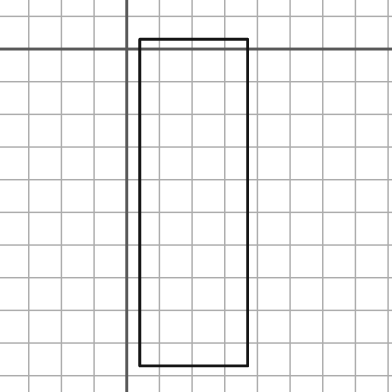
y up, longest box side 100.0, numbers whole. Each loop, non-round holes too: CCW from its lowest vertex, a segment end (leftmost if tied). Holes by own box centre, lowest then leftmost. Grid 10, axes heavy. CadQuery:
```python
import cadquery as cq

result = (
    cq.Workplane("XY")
    .moveTo(4.0, -97.0)
    .lineTo(37.0, -97.0)
    .lineTo(37.0, 3.0)
    .lineTo(4.0, 3.0)
    .close()
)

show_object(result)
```